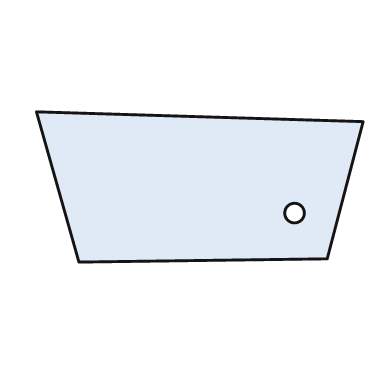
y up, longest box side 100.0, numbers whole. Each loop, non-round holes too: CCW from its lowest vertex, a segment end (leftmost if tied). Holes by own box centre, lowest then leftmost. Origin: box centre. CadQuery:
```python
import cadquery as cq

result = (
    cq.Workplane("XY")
    .moveTo(-37.0, -23.0)
    .lineTo(39.0, -22.0)
    .lineTo(50.0, 20.0)
    .lineTo(-50.0, 23.0)
    .close()
    .moveTo(29.0, -8.0)
    .circle(3.0)
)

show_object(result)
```